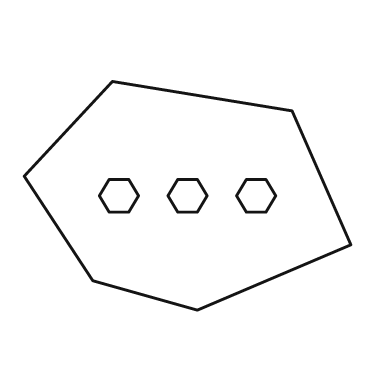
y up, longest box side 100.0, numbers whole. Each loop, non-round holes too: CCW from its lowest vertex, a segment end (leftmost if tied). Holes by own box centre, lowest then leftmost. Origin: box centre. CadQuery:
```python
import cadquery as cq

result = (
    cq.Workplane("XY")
    .moveTo(3.0, -35.0)
    .lineTo(50.0, -15.0)
    .lineTo(32.0, 26.0)
    .lineTo(-23.0, 35.0)
    .lineTo(-50.0, 6.0)
    .lineTo(-29.0, -26.0)
    .close()
    .moveTo(-24.0, -5.0)
    .lineTo(-18.0, -5.0)
    .lineTo(-15.0, 0.0)
    .lineTo(-18.0, 5.0)
    .lineTo(-24.0, 5.0)
    .lineTo(-27.0, 0.0)
    .close()
    .moveTo(-3.0, -5.0)
    .lineTo(3.0, -5.0)
    .lineTo(6.0, 0.0)
    .lineTo(3.0, 5.0)
    .lineTo(-3.0, 5.0)
    .lineTo(-6.0, 0.0)
    .close()
    .moveTo(18.0, -5.0)
    .lineTo(24.0, -5.0)
    .lineTo(27.0, 0.0)
    .lineTo(24.0, 5.0)
    .lineTo(18.0, 5.0)
    .lineTo(15.0, 0.0)
    .close()
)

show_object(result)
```